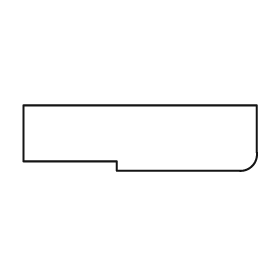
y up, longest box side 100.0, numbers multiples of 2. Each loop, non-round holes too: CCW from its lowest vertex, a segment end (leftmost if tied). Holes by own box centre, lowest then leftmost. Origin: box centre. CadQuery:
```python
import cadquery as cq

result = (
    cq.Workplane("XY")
    .moveTo(-10.0, -14.0)
    .lineTo(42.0, -14.0)
    .threePointArc((48.0, -12.0), (50.0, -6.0))
    .lineTo(50.0, 14.0)
    .lineTo(-50.0, 14.0)
    .lineTo(-50.0, -10.0)
    .lineTo(-10.0, -10.0)
    .close()
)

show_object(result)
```